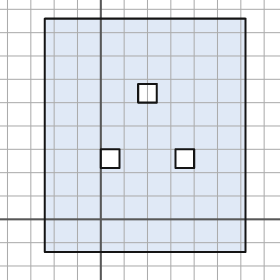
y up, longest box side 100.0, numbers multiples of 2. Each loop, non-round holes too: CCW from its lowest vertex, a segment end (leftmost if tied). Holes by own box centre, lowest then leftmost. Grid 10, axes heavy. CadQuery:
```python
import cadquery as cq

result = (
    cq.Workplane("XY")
    .moveTo(-24.0, -14.0)
    .lineTo(62.0, -14.0)
    .lineTo(62.0, 86.0)
    .lineTo(-24.0, 86.0)
    .close()
    .moveTo(0.0, 22.0)
    .lineTo(8.0, 22.0)
    .lineTo(8.0, 30.0)
    .lineTo(0.0, 30.0)
    .close()
    .moveTo(32.0, 22.0)
    .lineTo(40.0, 22.0)
    .lineTo(40.0, 30.0)
    .lineTo(32.0, 30.0)
    .close()
    .moveTo(16.0, 50.0)
    .lineTo(24.0, 50.0)
    .lineTo(24.0, 58.0)
    .lineTo(16.0, 58.0)
    .close()
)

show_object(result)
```